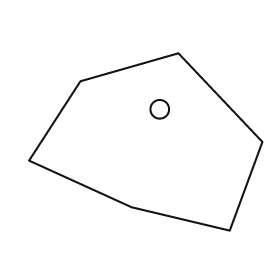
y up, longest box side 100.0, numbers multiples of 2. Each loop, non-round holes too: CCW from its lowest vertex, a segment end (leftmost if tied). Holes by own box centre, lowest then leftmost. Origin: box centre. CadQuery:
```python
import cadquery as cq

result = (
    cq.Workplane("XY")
    .moveTo(36.0, -38.0)
    .lineTo(50.0, 0.0)
    .lineTo(14.0, 38.0)
    .lineTo(-28.0, 26.0)
    .lineTo(-50.0, -8.0)
    .lineTo(-6.0, -28.0)
    .close()
    .moveTo(6.0, 14.0)
    .circle(4.0)
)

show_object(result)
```